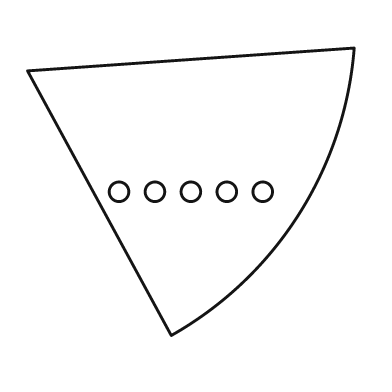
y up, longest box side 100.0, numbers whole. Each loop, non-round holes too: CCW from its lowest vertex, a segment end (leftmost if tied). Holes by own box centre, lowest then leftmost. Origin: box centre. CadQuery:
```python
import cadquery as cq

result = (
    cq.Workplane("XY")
    .moveTo(-6.0, -44.0)
    .threePointArc((33.0, -7.0), (50.0, 44.0))
    .lineTo(-50.0, 37.0)
    .close()
    .moveTo(-22.0, 0.0)
    .circle(3.0)
    .moveTo(-11.0, 0.0)
    .circle(3.0)
    .moveTo(0.0, 0.0)
    .circle(3.0)
    .moveTo(11.0, 0.0)
    .circle(3.0)
    .moveTo(22.0, 0.0)
    .circle(3.0)
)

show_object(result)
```